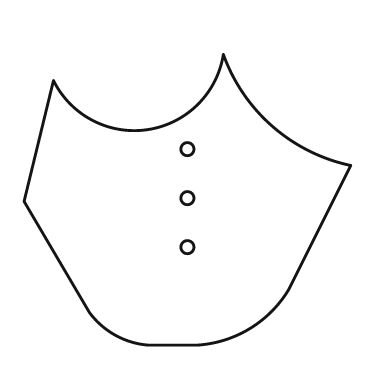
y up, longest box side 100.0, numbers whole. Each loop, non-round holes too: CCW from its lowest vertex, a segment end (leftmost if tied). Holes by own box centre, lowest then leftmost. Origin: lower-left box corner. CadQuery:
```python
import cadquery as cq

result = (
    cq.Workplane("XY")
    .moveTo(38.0, 0.0)
    .lineTo(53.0, 0.0)
    .threePointArc((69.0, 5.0), (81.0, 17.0))
    .lineTo(100.0, 55.0)
    .threePointArc((76.0, 67.0), (61.0, 89.0))
    .threePointArc((38.0, 66.0), (9.0, 81.0))
    .lineTo(0.0, 44.0)
    .lineTo(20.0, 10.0)
    .threePointArc((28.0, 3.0), (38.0, 0.0))
    .close()
    .moveTo(50.0, 30.0)
    .circle(2.0)
    .moveTo(50.0, 45.0)
    .circle(2.0)
    .moveTo(50.0, 60.0)
    .circle(2.0)
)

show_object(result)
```